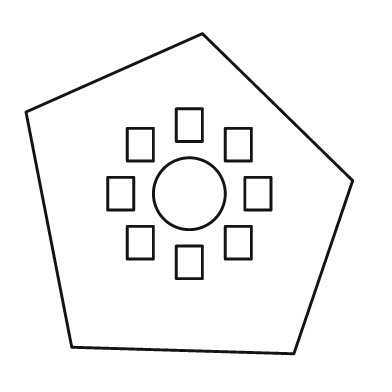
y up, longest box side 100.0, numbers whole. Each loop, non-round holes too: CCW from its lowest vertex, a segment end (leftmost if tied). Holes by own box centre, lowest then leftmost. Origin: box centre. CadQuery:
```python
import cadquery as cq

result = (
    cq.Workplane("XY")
    .moveTo(32.0, -49.0)
    .lineTo(50.0, 4.0)
    .lineTo(4.0, 49.0)
    .lineTo(-50.0, 25.0)
    .lineTo(-36.0, -47.0)
    .close()
    .moveTo(-4.0, -26.0)
    .lineTo(4.0, -26.0)
    .lineTo(4.0, -16.0)
    .lineTo(-4.0, -16.0)
    .close()
    .moveTo(-19.0, -20.0)
    .lineTo(-11.0, -20.0)
    .lineTo(-11.0, -10.0)
    .lineTo(-19.0, -10.0)
    .close()
    .moveTo(11.0, -20.0)
    .lineTo(19.0, -20.0)
    .lineTo(19.0, -10.0)
    .lineTo(11.0, -10.0)
    .close()
    .moveTo(-25.0, -5.0)
    .lineTo(-17.0, -5.0)
    .lineTo(-17.0, 5.0)
    .lineTo(-25.0, 5.0)
    .close()
    .moveTo(0.0, 0.0)
    .circle(11.0)
    .moveTo(17.0, -5.0)
    .lineTo(25.0, -5.0)
    .lineTo(25.0, 5.0)
    .lineTo(17.0, 5.0)
    .close()
    .moveTo(-19.0, 10.0)
    .lineTo(-11.0, 10.0)
    .lineTo(-11.0, 20.0)
    .lineTo(-19.0, 20.0)
    .close()
    .moveTo(11.0, 10.0)
    .lineTo(19.0, 10.0)
    .lineTo(19.0, 20.0)
    .lineTo(11.0, 20.0)
    .close()
    .moveTo(-4.0, 16.0)
    .lineTo(4.0, 16.0)
    .lineTo(4.0, 26.0)
    .lineTo(-4.0, 26.0)
    .close()
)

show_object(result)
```